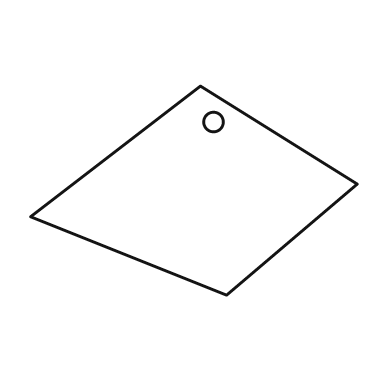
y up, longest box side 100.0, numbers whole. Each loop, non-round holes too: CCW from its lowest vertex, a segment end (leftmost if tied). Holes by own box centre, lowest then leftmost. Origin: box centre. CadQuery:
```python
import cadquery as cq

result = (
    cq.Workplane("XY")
    .moveTo(10.0, -32.0)
    .lineTo(50.0, 2.0)
    .lineTo(2.0, 32.0)
    .lineTo(-50.0, -8.0)
    .close()
    .moveTo(6.0, 21.0)
    .circle(3.0)
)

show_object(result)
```